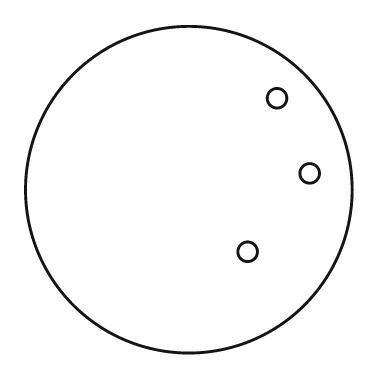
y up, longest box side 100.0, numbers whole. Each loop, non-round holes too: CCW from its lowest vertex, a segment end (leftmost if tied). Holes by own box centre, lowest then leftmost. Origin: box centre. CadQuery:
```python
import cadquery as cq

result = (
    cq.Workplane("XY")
    .moveTo(0.0, 0.0)
    .circle(50.0)
    .moveTo(18.0, -19.0)
    .circle(3.0)
    .moveTo(37.0, 5.0)
    .circle(3.0)
    .moveTo(27.0, 28.0)
    .circle(3.0)
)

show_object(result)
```